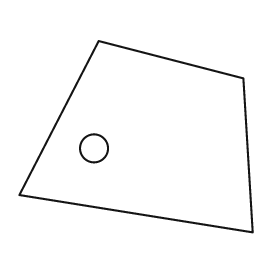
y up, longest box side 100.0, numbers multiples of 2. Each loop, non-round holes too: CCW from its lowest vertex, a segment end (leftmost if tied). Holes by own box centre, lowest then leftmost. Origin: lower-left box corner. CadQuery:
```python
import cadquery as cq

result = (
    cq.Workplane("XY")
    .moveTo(100.0, 0.0)
    .lineTo(96.0, 66.0)
    .lineTo(34.0, 82.0)
    .lineTo(0.0, 16.0)
    .close()
    .moveTo(32.0, 36.0)
    .circle(6.0)
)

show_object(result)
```